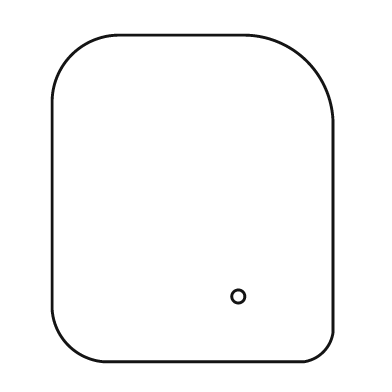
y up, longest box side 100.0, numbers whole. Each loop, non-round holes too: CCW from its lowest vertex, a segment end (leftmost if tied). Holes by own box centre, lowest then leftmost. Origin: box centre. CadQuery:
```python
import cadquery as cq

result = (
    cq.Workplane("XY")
    .moveTo(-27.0, -50.0)
    .lineTo(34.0, -50.0)
    .threePointArc((40.0, -47.0), (43.0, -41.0))
    .lineTo(43.0, 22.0)
    .threePointArc((35.0, 42.0), (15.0, 50.0))
    .lineTo(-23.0, 50.0)
    .threePointArc((-37.0, 44.0), (-43.0, 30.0))
    .lineTo(-43.0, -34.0)
    .threePointArc((-38.0, -45.0), (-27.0, -50.0))
    .close()
    .moveTo(14.0, -30.0)
    .circle(2.0)
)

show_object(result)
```